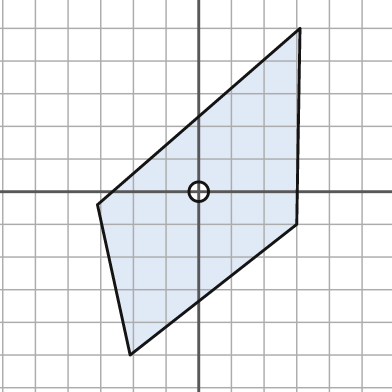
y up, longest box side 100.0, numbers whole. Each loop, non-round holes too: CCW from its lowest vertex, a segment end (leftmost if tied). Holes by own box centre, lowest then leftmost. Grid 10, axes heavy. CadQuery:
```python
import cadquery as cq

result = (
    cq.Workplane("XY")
    .moveTo(-21.0, -50.0)
    .lineTo(30.0, -10.0)
    .lineTo(31.0, 50.0)
    .lineTo(-31.0, -4.0)
    .close()
    .moveTo(0.0, 0.0)
    .circle(3.0)
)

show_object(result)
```